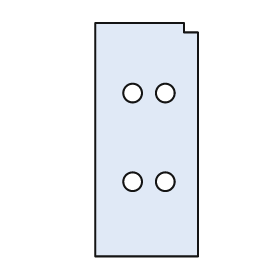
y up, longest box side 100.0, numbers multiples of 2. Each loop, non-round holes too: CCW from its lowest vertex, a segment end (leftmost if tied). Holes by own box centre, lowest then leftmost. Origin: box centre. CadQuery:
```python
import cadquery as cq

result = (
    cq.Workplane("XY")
    .moveTo(-22.0, -50.0)
    .lineTo(22.0, -50.0)
    .lineTo(22.0, 46.0)
    .lineTo(16.0, 46.0)
    .lineTo(16.0, 50.0)
    .lineTo(-22.0, 50.0)
    .close()
    .moveTo(-6.0, -18.0)
    .circle(4.0)
    .moveTo(8.0, -18.0)
    .circle(4.0)
    .moveTo(-6.0, 20.0)
    .circle(4.0)
    .moveTo(8.0, 20.0)
    .circle(4.0)
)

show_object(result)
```